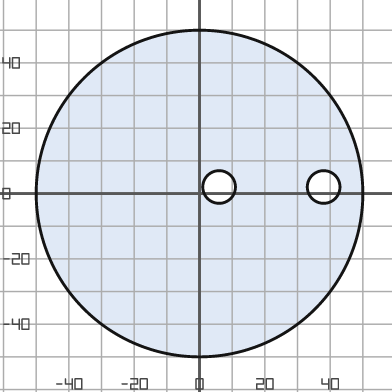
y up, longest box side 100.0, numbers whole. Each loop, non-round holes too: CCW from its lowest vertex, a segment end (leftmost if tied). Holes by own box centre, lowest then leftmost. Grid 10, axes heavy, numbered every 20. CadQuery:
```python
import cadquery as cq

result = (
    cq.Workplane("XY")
    .moveTo(0.0, 0.0)
    .circle(50.0)
    .moveTo(6.0, 2.0)
    .circle(5.0)
    .moveTo(38.0, 2.0)
    .circle(5.0)
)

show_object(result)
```